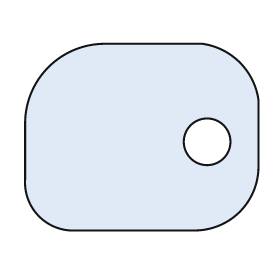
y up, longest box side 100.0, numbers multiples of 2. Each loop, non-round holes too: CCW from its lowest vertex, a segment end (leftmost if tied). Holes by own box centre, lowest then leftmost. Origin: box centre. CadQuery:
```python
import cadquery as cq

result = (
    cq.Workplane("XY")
    .moveTo(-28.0, -40.0)
    .lineTo(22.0, -40.0)
    .threePointArc((42.0, -32.0), (50.0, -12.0))
    .lineTo(50.0, 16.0)
    .threePointArc((42.0, 32.0), (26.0, 40.0))
    .lineTo(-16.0, 40.0)
    .threePointArc((-40.0, 30.0), (-50.0, 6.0))
    .lineTo(-50.0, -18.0)
    .threePointArc((-44.0, -34.0), (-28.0, -40.0))
    .close()
    .moveTo(28.0, -2.0)
    .circle(10.0)
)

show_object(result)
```